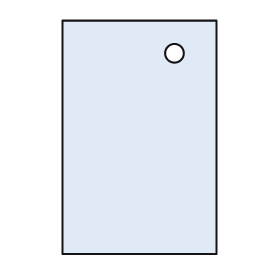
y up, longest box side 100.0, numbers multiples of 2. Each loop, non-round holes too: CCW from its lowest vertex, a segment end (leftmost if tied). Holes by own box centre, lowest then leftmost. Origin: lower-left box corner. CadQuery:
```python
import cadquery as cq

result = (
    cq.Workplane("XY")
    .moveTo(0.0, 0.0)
    .lineTo(66.0, 0.0)
    .lineTo(66.0, 100.0)
    .lineTo(0.0, 100.0)
    .close()
    .moveTo(48.0, 86.0)
    .circle(4.0)
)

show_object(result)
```